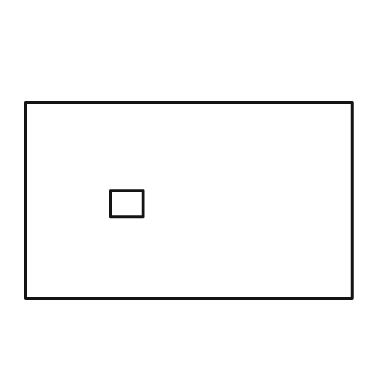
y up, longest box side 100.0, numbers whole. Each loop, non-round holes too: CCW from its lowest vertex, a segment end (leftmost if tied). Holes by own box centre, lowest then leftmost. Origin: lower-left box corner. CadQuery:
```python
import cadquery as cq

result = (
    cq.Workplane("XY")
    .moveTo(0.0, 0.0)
    .lineTo(100.0, 0.0)
    .lineTo(100.0, 60.0)
    .lineTo(0.0, 60.0)
    .close()
    .moveTo(26.0, 25.0)
    .lineTo(36.0, 25.0)
    .lineTo(36.0, 33.0)
    .lineTo(26.0, 33.0)
    .close()
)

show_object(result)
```